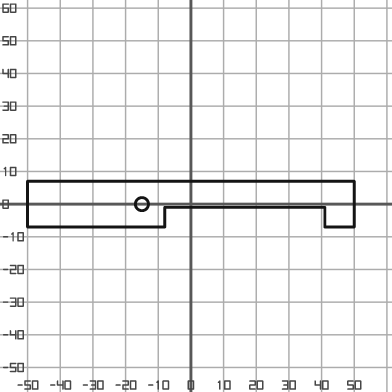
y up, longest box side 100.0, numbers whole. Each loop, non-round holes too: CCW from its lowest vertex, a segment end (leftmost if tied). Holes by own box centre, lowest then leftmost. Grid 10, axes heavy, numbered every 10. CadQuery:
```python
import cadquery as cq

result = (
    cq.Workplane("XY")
    .moveTo(-50.0, -7.0)
    .lineTo(-8.0, -7.0)
    .lineTo(-8.0, -1.0)
    .lineTo(41.0, -1.0)
    .lineTo(41.0, -7.0)
    .lineTo(50.0, -7.0)
    .lineTo(50.0, 7.0)
    .lineTo(-50.0, 7.0)
    .close()
    .moveTo(-15.0, 0.0)
    .circle(2.0)
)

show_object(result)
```